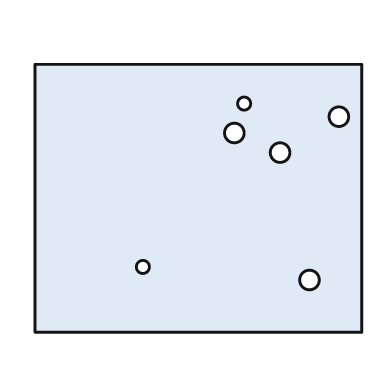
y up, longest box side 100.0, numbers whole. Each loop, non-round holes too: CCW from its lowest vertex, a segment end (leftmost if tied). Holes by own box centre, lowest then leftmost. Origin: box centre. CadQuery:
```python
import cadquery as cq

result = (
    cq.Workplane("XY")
    .moveTo(-50.0, -41.0)
    .lineTo(50.0, -41.0)
    .lineTo(50.0, 41.0)
    .lineTo(-50.0, 41.0)
    .close()
    .moveTo(34.0, -25.0)
    .circle(3.0)
    .moveTo(-17.0, -21.0)
    .circle(2.0)
    .moveTo(25.0, 14.0)
    .circle(3.0)
    .moveTo(11.0, 20.0)
    .circle(3.0)
    .moveTo(43.0, 25.0)
    .circle(3.0)
    .moveTo(14.0, 29.0)
    .circle(2.0)
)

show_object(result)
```